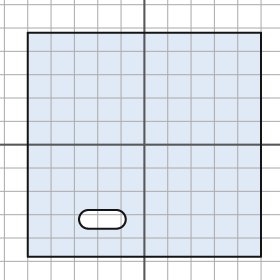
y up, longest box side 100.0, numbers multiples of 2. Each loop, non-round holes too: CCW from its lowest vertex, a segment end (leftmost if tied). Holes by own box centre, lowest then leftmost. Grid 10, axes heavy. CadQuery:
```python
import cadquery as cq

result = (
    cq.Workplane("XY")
    .moveTo(-50.0, -48.0)
    .lineTo(50.0, -48.0)
    .lineTo(50.0, 48.0)
    .lineTo(-50.0, 48.0)
    .close()
    .moveTo(-24.0, -36.0)
    .lineTo(-12.0, -36.0)
    .threePointArc((-8.0, -32.0), (-12.0, -28.0))
    .lineTo(-24.0, -28.0)
    .threePointArc((-28.0, -32.0), (-24.0, -36.0))
    .close()
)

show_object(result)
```